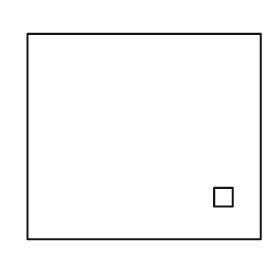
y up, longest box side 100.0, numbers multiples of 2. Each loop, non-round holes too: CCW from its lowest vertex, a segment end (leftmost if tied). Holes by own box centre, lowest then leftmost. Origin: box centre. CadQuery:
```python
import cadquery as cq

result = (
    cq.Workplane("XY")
    .moveTo(-50.0, -44.0)
    .lineTo(50.0, -44.0)
    .lineTo(50.0, 44.0)
    .lineTo(-50.0, 44.0)
    .close()
    .moveTo(30.0, -30.0)
    .lineTo(38.0, -30.0)
    .lineTo(38.0, -22.0)
    .lineTo(30.0, -22.0)
    .close()
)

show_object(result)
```